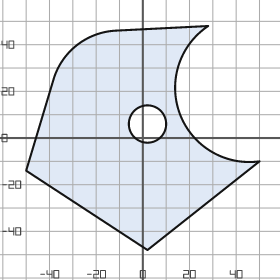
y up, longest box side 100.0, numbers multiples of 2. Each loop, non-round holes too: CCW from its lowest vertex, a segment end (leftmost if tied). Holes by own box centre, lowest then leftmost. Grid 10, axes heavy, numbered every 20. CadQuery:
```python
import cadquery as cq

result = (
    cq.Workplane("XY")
    .moveTo(2.0, -48.0)
    .lineTo(50.0, -10.0)
    .threePointArc((16.0, 10.0), (28.0, 48.0))
    .lineTo(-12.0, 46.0)
    .threePointArc((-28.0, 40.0), (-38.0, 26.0))
    .lineTo(-50.0, -14.0)
    .close()
    .moveTo(2.0, 6.0)
    .circle(8.0)
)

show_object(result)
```